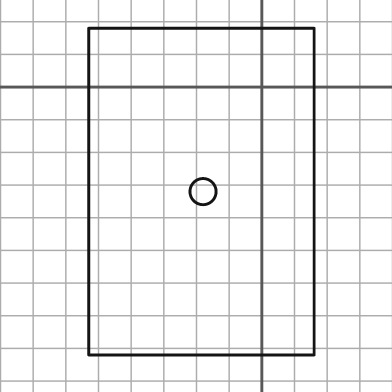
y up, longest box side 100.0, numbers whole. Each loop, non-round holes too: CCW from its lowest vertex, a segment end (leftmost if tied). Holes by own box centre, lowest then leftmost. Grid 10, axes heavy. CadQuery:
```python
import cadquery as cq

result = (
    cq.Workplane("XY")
    .moveTo(-53.0, -82.0)
    .lineTo(16.0, -82.0)
    .lineTo(16.0, 18.0)
    .lineTo(-53.0, 18.0)
    .close()
    .moveTo(-18.0, -32.0)
    .circle(4.0)
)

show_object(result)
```